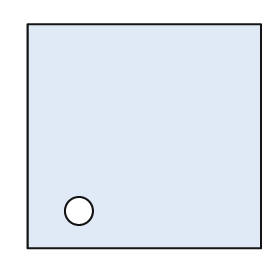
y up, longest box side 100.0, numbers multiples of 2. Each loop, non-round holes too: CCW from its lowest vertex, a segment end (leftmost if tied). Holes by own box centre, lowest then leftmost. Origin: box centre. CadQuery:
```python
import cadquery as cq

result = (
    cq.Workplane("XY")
    .moveTo(-50.0, -48.0)
    .lineTo(50.0, -48.0)
    .lineTo(50.0, 48.0)
    .lineTo(-50.0, 48.0)
    .close()
    .moveTo(-28.0, -32.0)
    .circle(6.0)
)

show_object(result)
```